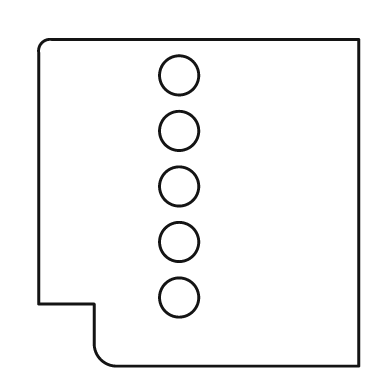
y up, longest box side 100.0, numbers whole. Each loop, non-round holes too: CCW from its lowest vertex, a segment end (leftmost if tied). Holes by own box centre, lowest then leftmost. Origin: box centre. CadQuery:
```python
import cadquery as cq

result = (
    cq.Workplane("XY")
    .moveTo(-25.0, -50.0)
    .lineTo(49.0, -50.0)
    .lineTo(49.0, 50.0)
    .lineTo(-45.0, 50.0)
    .threePointArc((-48.0, 49.0), (-49.0, 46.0))
    .lineTo(-49.0, -31.0)
    .lineTo(-32.0, -31.0)
    .lineTo(-32.0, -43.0)
    .threePointArc((-30.0, -48.0), (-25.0, -50.0))
    .close()
    .moveTo(-6.0, -29.0)
    .circle(6.0)
    .moveTo(-6.0, -12.0)
    .circle(6.0)
    .moveTo(-6.0, 5.0)
    .circle(6.0)
    .moveTo(-6.0, 22.0)
    .circle(6.0)
    .moveTo(-6.0, 39.0)
    .circle(6.0)
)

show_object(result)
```